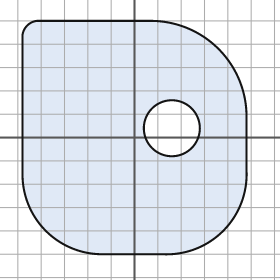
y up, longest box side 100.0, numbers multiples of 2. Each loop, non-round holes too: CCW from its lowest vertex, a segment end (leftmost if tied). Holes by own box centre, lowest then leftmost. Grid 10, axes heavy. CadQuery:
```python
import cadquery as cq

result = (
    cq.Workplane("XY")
    .moveTo(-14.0, -50.0)
    .lineTo(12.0, -50.0)
    .threePointArc((38.0, -40.0), (48.0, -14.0))
    .lineTo(48.0, 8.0)
    .threePointArc((36.0, 38.0), (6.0, 50.0))
    .lineTo(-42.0, 50.0)
    .threePointArc((-46.0, 48.0), (-48.0, 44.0))
    .lineTo(-48.0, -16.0)
    .threePointArc((-38.0, -40.0), (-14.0, -50.0))
    .close()
    .moveTo(16.0, 4.0)
    .circle(12.0)
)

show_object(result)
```